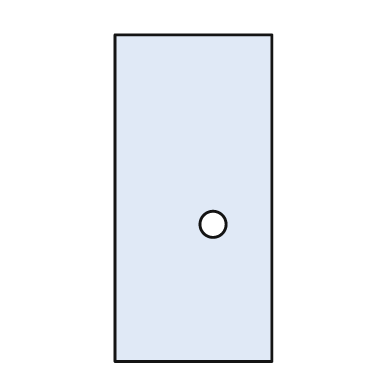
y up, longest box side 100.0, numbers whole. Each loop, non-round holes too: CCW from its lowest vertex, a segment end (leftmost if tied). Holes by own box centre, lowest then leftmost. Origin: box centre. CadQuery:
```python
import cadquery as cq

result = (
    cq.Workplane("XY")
    .moveTo(-24.0, -50.0)
    .lineTo(24.0, -50.0)
    .lineTo(24.0, 50.0)
    .lineTo(-24.0, 50.0)
    .close()
    .moveTo(6.0, -8.0)
    .circle(4.0)
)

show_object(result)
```